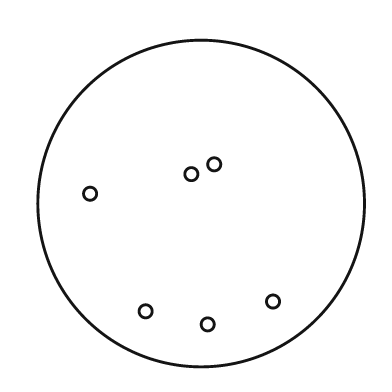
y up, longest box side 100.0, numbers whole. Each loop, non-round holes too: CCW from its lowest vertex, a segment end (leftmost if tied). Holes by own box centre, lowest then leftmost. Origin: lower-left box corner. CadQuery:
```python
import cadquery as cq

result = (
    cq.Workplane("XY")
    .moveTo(50.0, 50.0)
    .circle(50.0)
    .moveTo(52.0, 13.0)
    .circle(2.0)
    .moveTo(33.0, 17.0)
    .circle(2.0)
    .moveTo(72.0, 20.0)
    .circle(2.0)
    .moveTo(16.0, 53.0)
    .circle(2.0)
    .moveTo(47.0, 59.0)
    .circle(2.0)
    .moveTo(54.0, 62.0)
    .circle(2.0)
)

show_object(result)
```